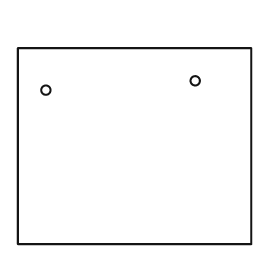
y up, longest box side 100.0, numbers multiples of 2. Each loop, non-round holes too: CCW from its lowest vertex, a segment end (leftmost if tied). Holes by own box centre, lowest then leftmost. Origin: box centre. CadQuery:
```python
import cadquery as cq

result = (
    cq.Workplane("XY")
    .moveTo(-50.0, -42.0)
    .lineTo(50.0, -42.0)
    .lineTo(50.0, 42.0)
    .lineTo(-50.0, 42.0)
    .close()
    .moveTo(-38.0, 24.0)
    .circle(2.0)
    .moveTo(26.0, 28.0)
    .circle(2.0)
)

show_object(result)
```